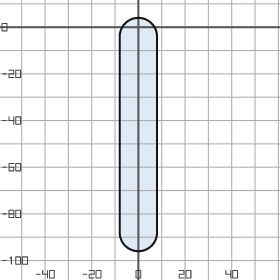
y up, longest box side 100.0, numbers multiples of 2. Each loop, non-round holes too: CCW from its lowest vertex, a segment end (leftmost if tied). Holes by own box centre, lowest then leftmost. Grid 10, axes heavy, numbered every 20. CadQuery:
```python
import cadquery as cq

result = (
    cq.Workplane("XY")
    .moveTo(-8.0, -88.0)
    .threePointArc((0.0, -96.0), (8.0, -88.0))
    .lineTo(8.0, -4.0)
    .threePointArc((0.0, 4.0), (-8.0, -4.0))
    .close()
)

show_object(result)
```